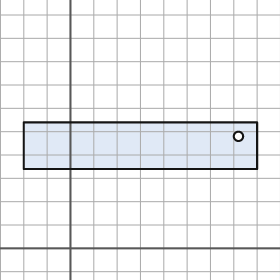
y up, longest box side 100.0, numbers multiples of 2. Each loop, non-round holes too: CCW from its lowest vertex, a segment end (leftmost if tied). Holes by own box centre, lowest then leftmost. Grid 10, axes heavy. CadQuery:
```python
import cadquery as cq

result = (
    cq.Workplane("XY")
    .moveTo(-20.0, 34.0)
    .lineTo(80.0, 34.0)
    .lineTo(80.0, 54.0)
    .lineTo(-20.0, 54.0)
    .close()
    .moveTo(72.0, 48.0)
    .circle(2.0)
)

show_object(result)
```